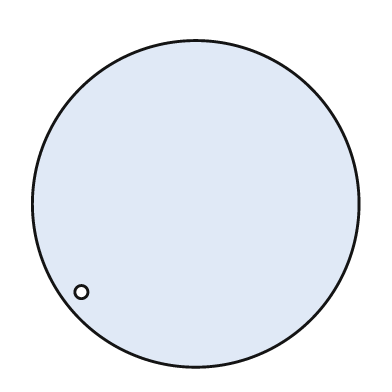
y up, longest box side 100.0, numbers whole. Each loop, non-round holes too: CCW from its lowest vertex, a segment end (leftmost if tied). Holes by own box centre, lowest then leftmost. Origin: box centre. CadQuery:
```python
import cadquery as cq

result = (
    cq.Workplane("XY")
    .moveTo(0.0, 0.0)
    .circle(50.0)
    .moveTo(-35.0, -27.0)
    .circle(2.0)
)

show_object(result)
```